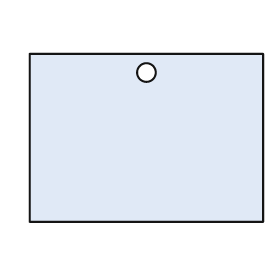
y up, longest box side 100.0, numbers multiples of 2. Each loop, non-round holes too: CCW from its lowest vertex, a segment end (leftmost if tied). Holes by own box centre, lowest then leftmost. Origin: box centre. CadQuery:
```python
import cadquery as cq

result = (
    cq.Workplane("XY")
    .moveTo(-50.0, -36.0)
    .lineTo(50.0, -36.0)
    .lineTo(50.0, 36.0)
    .lineTo(-50.0, 36.0)
    .close()
    .moveTo(0.0, 28.0)
    .circle(4.0)
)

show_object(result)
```